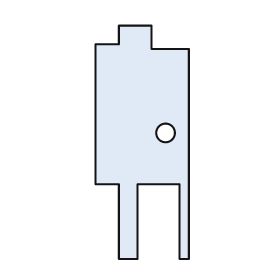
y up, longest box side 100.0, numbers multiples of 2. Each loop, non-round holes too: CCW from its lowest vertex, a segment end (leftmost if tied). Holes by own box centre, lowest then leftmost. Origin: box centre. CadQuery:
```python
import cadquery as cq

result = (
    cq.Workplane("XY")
    .moveTo(-10.0, -50.0)
    .lineTo(-2.0, -50.0)
    .lineTo(-2.0, -18.0)
    .lineTo(16.0, -18.0)
    .lineTo(16.0, -50.0)
    .lineTo(20.0, -50.0)
    .lineTo(20.0, 40.0)
    .lineTo(4.0, 40.0)
    .lineTo(4.0, 50.0)
    .lineTo(-10.0, 50.0)
    .lineTo(-10.0, 42.0)
    .lineTo(-20.0, 42.0)
    .lineTo(-20.0, -18.0)
    .lineTo(-10.0, -18.0)
    .close()
    .moveTo(10.0, 4.0)
    .circle(4.0)
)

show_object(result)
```